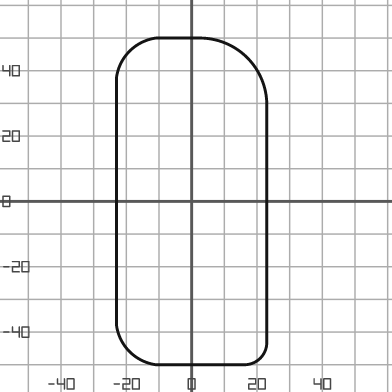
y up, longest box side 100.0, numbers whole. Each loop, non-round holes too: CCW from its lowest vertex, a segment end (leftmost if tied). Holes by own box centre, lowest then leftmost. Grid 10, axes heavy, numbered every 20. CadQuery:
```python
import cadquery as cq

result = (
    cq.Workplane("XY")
    .moveTo(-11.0, -50.0)
    .lineTo(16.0, -50.0)
    .threePointArc((21.0, -48.0), (23.0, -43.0))
    .lineTo(23.0, 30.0)
    .threePointArc((17.0, 44.0), (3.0, 50.0))
    .lineTo(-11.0, 50.0)
    .threePointArc((-19.0, 46.0), (-23.0, 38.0))
    .lineTo(-23.0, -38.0)
    .threePointArc((-19.0, -46.0), (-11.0, -50.0))
    .close()
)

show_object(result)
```